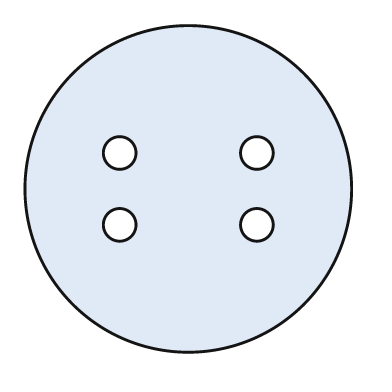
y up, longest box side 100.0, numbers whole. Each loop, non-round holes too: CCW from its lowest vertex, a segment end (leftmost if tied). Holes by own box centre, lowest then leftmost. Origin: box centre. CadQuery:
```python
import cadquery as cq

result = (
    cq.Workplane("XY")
    .moveTo(0.0, 0.0)
    .circle(50.0)
    .moveTo(-21.0, -11.0)
    .circle(5.0)
    .moveTo(21.0, -11.0)
    .circle(5.0)
    .moveTo(-21.0, 11.0)
    .circle(5.0)
    .moveTo(21.0, 11.0)
    .circle(5.0)
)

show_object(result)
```